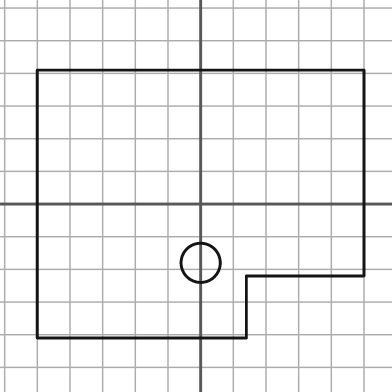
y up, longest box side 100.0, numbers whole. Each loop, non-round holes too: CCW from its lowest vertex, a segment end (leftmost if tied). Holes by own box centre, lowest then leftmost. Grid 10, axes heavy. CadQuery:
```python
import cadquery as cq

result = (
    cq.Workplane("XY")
    .moveTo(-50.0, -41.0)
    .lineTo(14.0, -41.0)
    .lineTo(14.0, -22.0)
    .lineTo(50.0, -22.0)
    .lineTo(50.0, 41.0)
    .lineTo(-50.0, 41.0)
    .close()
    .moveTo(0.0, -18.0)
    .circle(6.0)
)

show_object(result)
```